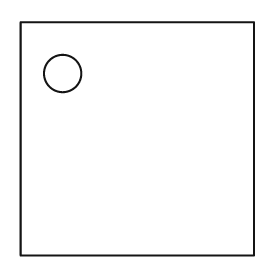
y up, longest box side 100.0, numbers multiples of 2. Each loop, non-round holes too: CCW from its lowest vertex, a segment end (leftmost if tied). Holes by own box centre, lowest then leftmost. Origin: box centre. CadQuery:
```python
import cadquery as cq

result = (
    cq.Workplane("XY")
    .moveTo(-50.0, -50.0)
    .lineTo(50.0, -50.0)
    .lineTo(50.0, 50.0)
    .lineTo(-50.0, 50.0)
    .close()
    .moveTo(-32.0, 28.0)
    .circle(8.0)
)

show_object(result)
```